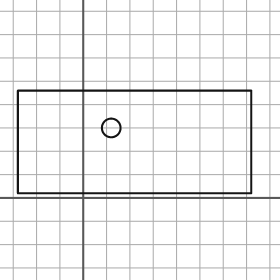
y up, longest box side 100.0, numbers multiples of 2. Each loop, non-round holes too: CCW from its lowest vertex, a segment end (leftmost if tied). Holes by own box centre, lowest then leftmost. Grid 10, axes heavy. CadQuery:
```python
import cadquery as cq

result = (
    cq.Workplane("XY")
    .moveTo(-28.0, 2.0)
    .lineTo(72.0, 2.0)
    .lineTo(72.0, 46.0)
    .lineTo(-28.0, 46.0)
    .close()
    .moveTo(12.0, 30.0)
    .circle(4.0)
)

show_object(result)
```